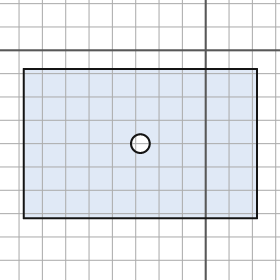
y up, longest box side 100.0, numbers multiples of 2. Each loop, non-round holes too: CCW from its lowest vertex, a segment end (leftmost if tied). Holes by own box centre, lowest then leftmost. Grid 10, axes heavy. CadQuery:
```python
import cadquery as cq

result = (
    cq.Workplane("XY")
    .moveTo(-78.0, -72.0)
    .lineTo(22.0, -72.0)
    .lineTo(22.0, -8.0)
    .lineTo(-78.0, -8.0)
    .close()
    .moveTo(-28.0, -40.0)
    .circle(4.0)
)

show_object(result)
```